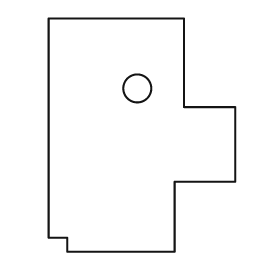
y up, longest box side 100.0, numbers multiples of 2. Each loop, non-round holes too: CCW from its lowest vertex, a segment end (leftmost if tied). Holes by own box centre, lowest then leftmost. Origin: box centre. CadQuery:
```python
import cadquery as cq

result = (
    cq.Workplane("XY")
    .moveTo(-32.0, -50.0)
    .lineTo(14.0, -50.0)
    .lineTo(14.0, -20.0)
    .lineTo(40.0, -20.0)
    .lineTo(40.0, 12.0)
    .lineTo(18.0, 12.0)
    .lineTo(18.0, 50.0)
    .lineTo(-40.0, 50.0)
    .lineTo(-40.0, -44.0)
    .lineTo(-32.0, -44.0)
    .close()
    .moveTo(-2.0, 20.0)
    .circle(6.0)
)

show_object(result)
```